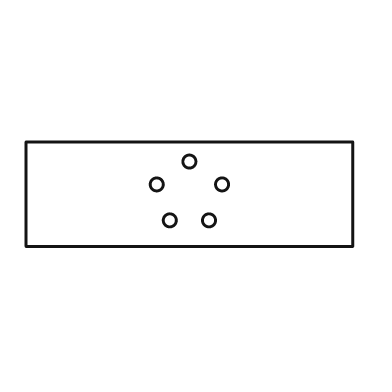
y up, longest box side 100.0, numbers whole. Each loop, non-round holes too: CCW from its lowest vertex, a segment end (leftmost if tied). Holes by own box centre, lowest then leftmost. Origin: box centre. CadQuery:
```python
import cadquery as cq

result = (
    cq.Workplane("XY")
    .moveTo(-50.0, -16.0)
    .lineTo(50.0, -16.0)
    .lineTo(50.0, 16.0)
    .lineTo(-50.0, 16.0)
    .close()
    .moveTo(-6.0, -8.0)
    .circle(2.0)
    .moveTo(6.0, -8.0)
    .circle(2.0)
    .moveTo(-10.0, 3.0)
    .circle(2.0)
    .moveTo(10.0, 3.0)
    .circle(2.0)
    .moveTo(0.0, 10.0)
    .circle(2.0)
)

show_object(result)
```